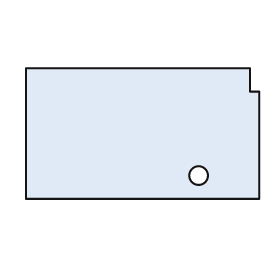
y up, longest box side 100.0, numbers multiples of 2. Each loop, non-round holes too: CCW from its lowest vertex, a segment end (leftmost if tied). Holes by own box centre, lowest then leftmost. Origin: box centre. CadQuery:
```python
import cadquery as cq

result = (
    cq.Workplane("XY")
    .moveTo(-50.0, -28.0)
    .lineTo(50.0, -28.0)
    .lineTo(50.0, 18.0)
    .lineTo(46.0, 18.0)
    .lineTo(46.0, 28.0)
    .lineTo(-50.0, 28.0)
    .close()
    .moveTo(24.0, -18.0)
    .circle(4.0)
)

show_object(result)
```